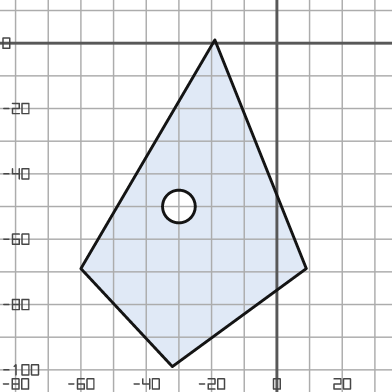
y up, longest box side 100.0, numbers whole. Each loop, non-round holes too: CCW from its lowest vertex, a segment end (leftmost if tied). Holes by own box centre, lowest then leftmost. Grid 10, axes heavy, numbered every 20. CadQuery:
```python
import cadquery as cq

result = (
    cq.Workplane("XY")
    .moveTo(-32.0, -99.0)
    .lineTo(9.0, -69.0)
    .lineTo(-19.0, 1.0)
    .lineTo(-60.0, -69.0)
    .close()
    .moveTo(-30.0, -50.0)
    .circle(5.0)
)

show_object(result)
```